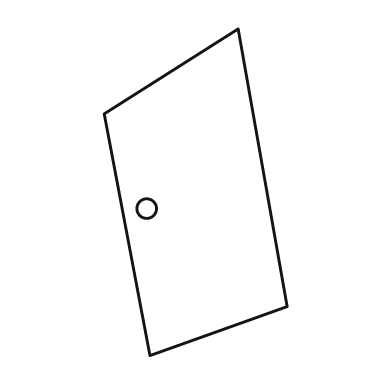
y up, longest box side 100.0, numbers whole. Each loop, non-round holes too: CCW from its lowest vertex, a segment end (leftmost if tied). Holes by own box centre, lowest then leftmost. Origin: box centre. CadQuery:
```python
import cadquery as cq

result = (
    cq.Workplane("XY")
    .moveTo(-14.0, -50.0)
    .lineTo(28.0, -35.0)
    .lineTo(13.0, 50.0)
    .lineTo(-28.0, 24.0)
    .close()
    .moveTo(-15.0, -5.0)
    .circle(3.0)
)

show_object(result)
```